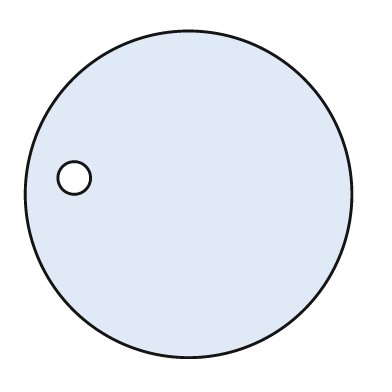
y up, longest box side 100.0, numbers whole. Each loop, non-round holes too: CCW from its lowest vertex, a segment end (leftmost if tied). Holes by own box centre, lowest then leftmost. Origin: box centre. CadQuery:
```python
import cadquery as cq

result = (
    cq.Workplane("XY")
    .moveTo(0.0, 0.0)
    .circle(50.0)
    .moveTo(-35.0, 5.0)
    .circle(5.0)
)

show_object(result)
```